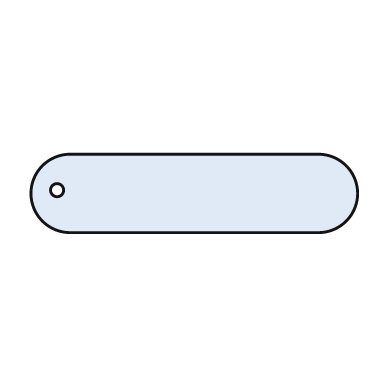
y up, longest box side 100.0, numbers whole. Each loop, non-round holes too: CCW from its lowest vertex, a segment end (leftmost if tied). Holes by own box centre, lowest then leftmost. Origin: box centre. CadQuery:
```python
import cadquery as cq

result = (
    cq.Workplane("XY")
    .moveTo(-38.0, -12.0)
    .lineTo(38.0, -12.0)
    .threePointArc((50.0, 0.0), (38.0, 12.0))
    .lineTo(-38.0, 12.0)
    .threePointArc((-50.0, 0.0), (-38.0, -12.0))
    .close()
    .moveTo(-42.0, 1.0)
    .circle(2.0)
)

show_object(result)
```